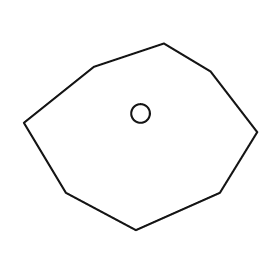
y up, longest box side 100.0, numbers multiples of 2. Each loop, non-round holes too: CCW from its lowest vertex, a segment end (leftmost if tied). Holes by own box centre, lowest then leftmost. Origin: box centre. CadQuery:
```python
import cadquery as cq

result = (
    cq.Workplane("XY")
    .moveTo(-2.0, -40.0)
    .lineTo(34.0, -24.0)
    .lineTo(50.0, 2.0)
    .lineTo(30.0, 28.0)
    .lineTo(10.0, 40.0)
    .lineTo(-20.0, 30.0)
    .lineTo(-50.0, 6.0)
    .lineTo(-32.0, -24.0)
    .close()
    .moveTo(0.0, 10.0)
    .circle(4.0)
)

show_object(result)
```